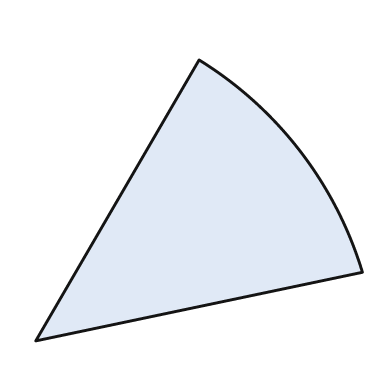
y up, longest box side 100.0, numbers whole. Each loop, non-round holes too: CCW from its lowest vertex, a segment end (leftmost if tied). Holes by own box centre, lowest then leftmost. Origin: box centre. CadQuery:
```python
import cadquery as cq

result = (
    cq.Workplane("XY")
    .moveTo(-50.0, -43.0)
    .lineTo(50.0, -22.0)
    .threePointArc((31.0, 15.0), (0.0, 43.0))
    .close()
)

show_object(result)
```